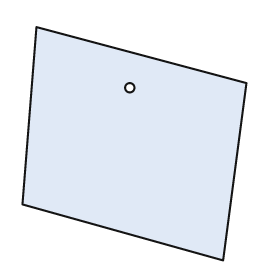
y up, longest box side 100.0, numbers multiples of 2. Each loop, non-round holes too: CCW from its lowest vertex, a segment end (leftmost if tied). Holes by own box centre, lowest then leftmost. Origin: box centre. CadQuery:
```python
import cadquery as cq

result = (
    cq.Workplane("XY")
    .moveTo(38.0, -50.0)
    .lineTo(48.0, 26.0)
    .lineTo(-42.0, 50.0)
    .lineTo(-48.0, -26.0)
    .close()
    .moveTo(-2.0, 24.0)
    .circle(2.0)
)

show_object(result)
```